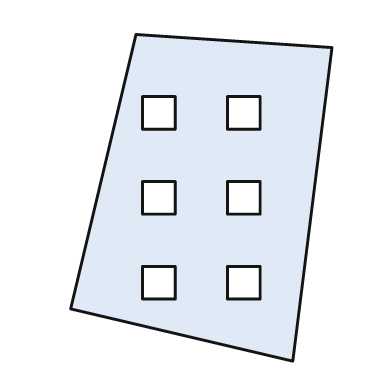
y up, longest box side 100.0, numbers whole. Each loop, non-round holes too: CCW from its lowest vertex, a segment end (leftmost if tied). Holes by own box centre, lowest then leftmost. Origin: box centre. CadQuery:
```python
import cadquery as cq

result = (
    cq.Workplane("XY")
    .moveTo(28.0, -50.0)
    .lineTo(40.0, 46.0)
    .lineTo(-20.0, 50.0)
    .lineTo(-40.0, -34.0)
    .close()
    .moveTo(-18.0, -31.0)
    .lineTo(-8.0, -31.0)
    .lineTo(-8.0, -21.0)
    .lineTo(-18.0, -21.0)
    .close()
    .moveTo(8.0, -31.0)
    .lineTo(18.0, -31.0)
    .lineTo(18.0, -21.0)
    .lineTo(8.0, -21.0)
    .close()
    .moveTo(-18.0, -5.0)
    .lineTo(-8.0, -5.0)
    .lineTo(-8.0, 5.0)
    .lineTo(-18.0, 5.0)
    .close()
    .moveTo(8.0, -5.0)
    .lineTo(18.0, -5.0)
    .lineTo(18.0, 5.0)
    .lineTo(8.0, 5.0)
    .close()
    .moveTo(-18.0, 21.0)
    .lineTo(-8.0, 21.0)
    .lineTo(-8.0, 31.0)
    .lineTo(-18.0, 31.0)
    .close()
    .moveTo(8.0, 21.0)
    .lineTo(18.0, 21.0)
    .lineTo(18.0, 31.0)
    .lineTo(8.0, 31.0)
    .close()
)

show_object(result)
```